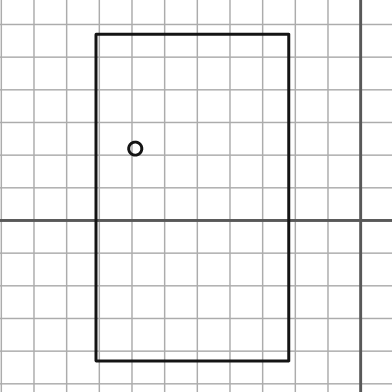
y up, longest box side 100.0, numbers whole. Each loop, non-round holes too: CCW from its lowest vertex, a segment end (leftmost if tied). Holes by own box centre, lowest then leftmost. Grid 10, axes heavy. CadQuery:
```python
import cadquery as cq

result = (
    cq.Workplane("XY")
    .moveTo(-81.0, -43.0)
    .lineTo(-22.0, -43.0)
    .lineTo(-22.0, 57.0)
    .lineTo(-81.0, 57.0)
    .close()
    .moveTo(-69.0, 22.0)
    .circle(2.0)
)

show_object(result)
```